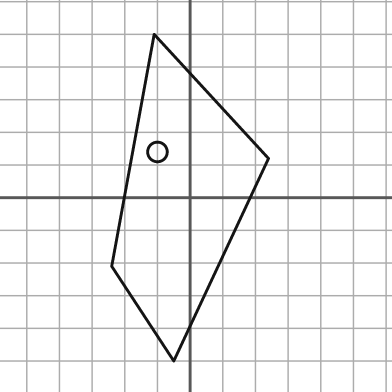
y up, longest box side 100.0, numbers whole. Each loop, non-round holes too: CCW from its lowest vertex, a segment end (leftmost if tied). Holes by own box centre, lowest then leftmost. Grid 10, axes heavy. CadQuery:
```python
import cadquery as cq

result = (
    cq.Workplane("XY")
    .moveTo(-5.0, -50.0)
    .lineTo(24.0, 12.0)
    .lineTo(-11.0, 50.0)
    .lineTo(-24.0, -21.0)
    .close()
    .moveTo(-10.0, 14.0)
    .circle(3.0)
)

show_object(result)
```